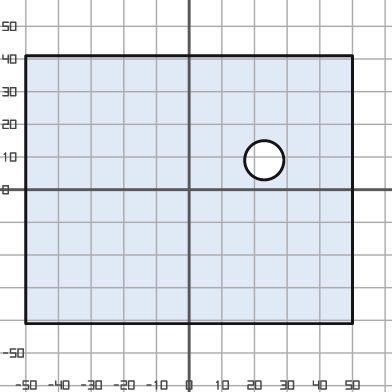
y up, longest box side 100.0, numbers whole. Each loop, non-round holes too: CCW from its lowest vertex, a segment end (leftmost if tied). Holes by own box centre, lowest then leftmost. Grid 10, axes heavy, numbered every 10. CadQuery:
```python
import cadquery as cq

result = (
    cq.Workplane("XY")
    .moveTo(-50.0, -41.0)
    .lineTo(50.0, -41.0)
    .lineTo(50.0, 41.0)
    .lineTo(-50.0, 41.0)
    .close()
    .moveTo(23.0, 9.0)
    .circle(6.0)
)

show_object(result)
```